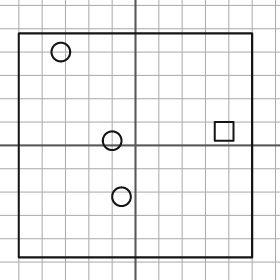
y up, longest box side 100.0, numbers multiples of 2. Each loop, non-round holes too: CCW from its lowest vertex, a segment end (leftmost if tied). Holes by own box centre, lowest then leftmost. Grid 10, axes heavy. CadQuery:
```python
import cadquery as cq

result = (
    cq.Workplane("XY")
    .moveTo(-50.0, -48.0)
    .lineTo(50.0, -48.0)
    .lineTo(50.0, 48.0)
    .lineTo(-50.0, 48.0)
    .close()
    .moveTo(-6.0, -22.0)
    .circle(4.0)
    .moveTo(-10.0, 2.0)
    .circle(4.0)
    .moveTo(34.0, 2.0)
    .lineTo(42.0, 2.0)
    .lineTo(42.0, 10.0)
    .lineTo(34.0, 10.0)
    .close()
    .moveTo(-32.0, 40.0)
    .circle(4.0)
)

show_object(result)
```